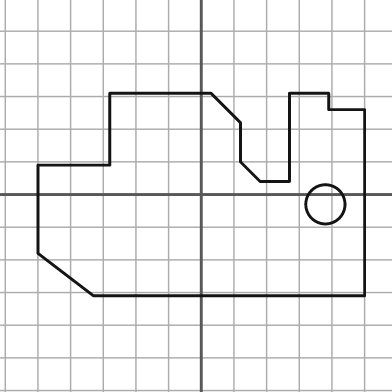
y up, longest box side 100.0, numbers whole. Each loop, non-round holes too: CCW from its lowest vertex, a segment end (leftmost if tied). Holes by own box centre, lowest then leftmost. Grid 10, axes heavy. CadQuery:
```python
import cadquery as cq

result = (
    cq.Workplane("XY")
    .moveTo(-33.0, -31.0)
    .lineTo(50.0, -31.0)
    .lineTo(50.0, 26.0)
    .lineTo(39.0, 26.0)
    .lineTo(39.0, 31.0)
    .lineTo(27.0, 31.0)
    .lineTo(27.0, 4.0)
    .lineTo(18.0, 4.0)
    .lineTo(12.0, 10.0)
    .lineTo(12.0, 22.0)
    .lineTo(3.0, 31.0)
    .lineTo(-28.0, 31.0)
    .lineTo(-28.0, 9.0)
    .lineTo(-50.0, 9.0)
    .lineTo(-50.0, -18.0)
    .close()
    .moveTo(38.0, -3.0)
    .circle(6.0)
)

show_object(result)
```